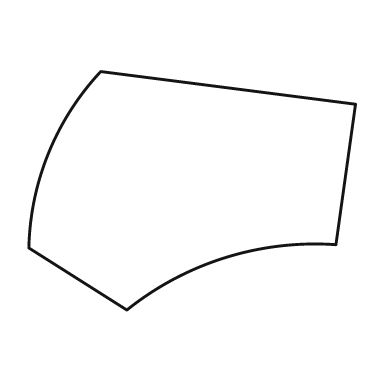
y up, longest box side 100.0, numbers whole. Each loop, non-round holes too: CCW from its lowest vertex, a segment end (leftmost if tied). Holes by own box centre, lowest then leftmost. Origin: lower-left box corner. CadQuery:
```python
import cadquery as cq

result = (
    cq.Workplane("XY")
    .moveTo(30.0, 0.0)
    .threePointArc((60.0, 16.0), (94.0, 20.0))
    .lineTo(100.0, 63.0)
    .lineTo(22.0, 73.0)
    .threePointArc((6.0, 48.0), (0.0, 19.0))
    .close()
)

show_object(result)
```